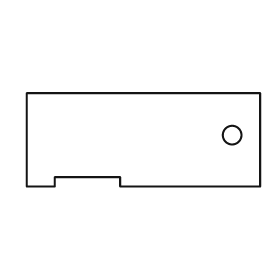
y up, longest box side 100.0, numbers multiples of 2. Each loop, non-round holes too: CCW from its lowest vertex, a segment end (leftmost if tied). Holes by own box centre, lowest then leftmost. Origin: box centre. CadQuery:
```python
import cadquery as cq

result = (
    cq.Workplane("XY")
    .moveTo(-50.0, -20.0)
    .lineTo(-38.0, -20.0)
    .lineTo(-38.0, -16.0)
    .lineTo(-10.0, -16.0)
    .lineTo(-10.0, -20.0)
    .lineTo(50.0, -20.0)
    .lineTo(50.0, 20.0)
    .lineTo(-50.0, 20.0)
    .close()
    .moveTo(38.0, 2.0)
    .circle(4.0)
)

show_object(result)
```